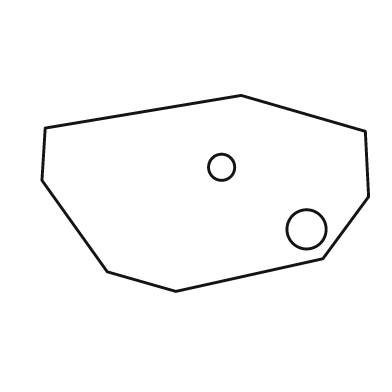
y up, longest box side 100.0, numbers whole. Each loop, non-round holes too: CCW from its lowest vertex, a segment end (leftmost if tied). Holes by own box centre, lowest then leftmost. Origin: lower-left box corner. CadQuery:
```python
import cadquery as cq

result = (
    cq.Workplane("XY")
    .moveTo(41.0, 0.0)
    .lineTo(86.0, 10.0)
    .lineTo(100.0, 29.0)
    .lineTo(99.0, 49.0)
    .lineTo(61.0, 60.0)
    .lineTo(1.0, 50.0)
    .lineTo(0.0, 34.0)
    .lineTo(20.0, 6.0)
    .close()
    .moveTo(81.0, 19.0)
    .circle(6.0)
    .moveTo(55.0, 38.0)
    .circle(4.0)
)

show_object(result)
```